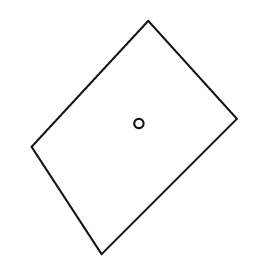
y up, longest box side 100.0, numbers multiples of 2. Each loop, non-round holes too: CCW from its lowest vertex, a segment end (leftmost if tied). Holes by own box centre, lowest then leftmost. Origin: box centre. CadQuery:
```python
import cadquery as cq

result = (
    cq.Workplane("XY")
    .moveTo(-14.0, -50.0)
    .lineTo(44.0, 8.0)
    .lineTo(6.0, 50.0)
    .lineTo(-44.0, -4.0)
    .close()
    .moveTo(2.0, 6.0)
    .circle(2.0)
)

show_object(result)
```